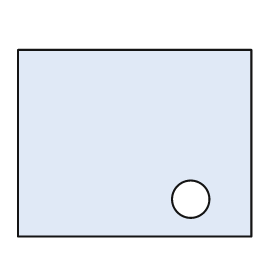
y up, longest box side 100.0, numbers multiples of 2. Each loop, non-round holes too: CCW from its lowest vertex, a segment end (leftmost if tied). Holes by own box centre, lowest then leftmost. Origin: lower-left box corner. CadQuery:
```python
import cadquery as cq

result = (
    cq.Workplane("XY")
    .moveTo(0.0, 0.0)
    .lineTo(100.0, 0.0)
    .lineTo(100.0, 80.0)
    .lineTo(0.0, 80.0)
    .close()
    .moveTo(74.0, 16.0)
    .circle(8.0)
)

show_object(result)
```